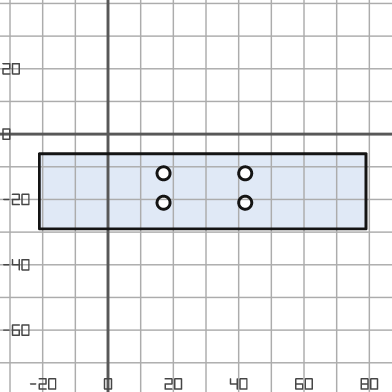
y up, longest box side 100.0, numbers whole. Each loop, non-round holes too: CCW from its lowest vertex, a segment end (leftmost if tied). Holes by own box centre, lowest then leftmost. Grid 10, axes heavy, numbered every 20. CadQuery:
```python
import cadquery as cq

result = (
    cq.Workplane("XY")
    .moveTo(-21.0, -29.0)
    .lineTo(79.0, -29.0)
    .lineTo(79.0, -6.0)
    .lineTo(-21.0, -6.0)
    .close()
    .moveTo(17.0, -21.0)
    .circle(2.0)
    .moveTo(42.0, -21.0)
    .circle(2.0)
    .moveTo(17.0, -12.0)
    .circle(2.0)
    .moveTo(42.0, -12.0)
    .circle(2.0)
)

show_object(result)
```